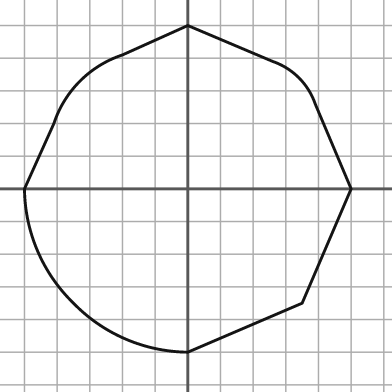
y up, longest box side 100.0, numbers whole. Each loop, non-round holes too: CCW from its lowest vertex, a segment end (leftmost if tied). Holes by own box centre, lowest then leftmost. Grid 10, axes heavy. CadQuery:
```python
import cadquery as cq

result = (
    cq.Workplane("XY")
    .moveTo(0.0, -50.0)
    .lineTo(35.0, -35.0)
    .lineTo(50.0, 0.0)
    .lineTo(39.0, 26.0)
    .threePointArc((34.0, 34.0), (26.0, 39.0))
    .lineTo(0.0, 50.0)
    .lineTo(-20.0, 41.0)
    .threePointArc((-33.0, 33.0), (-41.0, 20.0))
    .lineTo(-50.0, 0.0)
    .threePointArc((-46.0, -19.0), (-35.0, -35.0))
    .threePointArc((-19.0, -46.0), (0.0, -50.0))
    .close()
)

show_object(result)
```